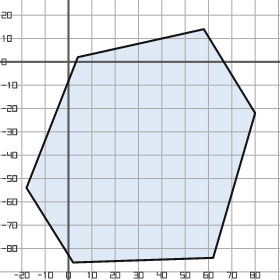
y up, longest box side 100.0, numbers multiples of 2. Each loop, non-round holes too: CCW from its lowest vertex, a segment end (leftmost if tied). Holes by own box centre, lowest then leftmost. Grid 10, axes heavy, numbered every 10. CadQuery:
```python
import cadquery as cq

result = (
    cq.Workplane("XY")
    .moveTo(2.0, -86.0)
    .lineTo(62.0, -84.0)
    .lineTo(80.0, -22.0)
    .lineTo(58.0, 14.0)
    .lineTo(4.0, 2.0)
    .lineTo(-18.0, -54.0)
    .close()
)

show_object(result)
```